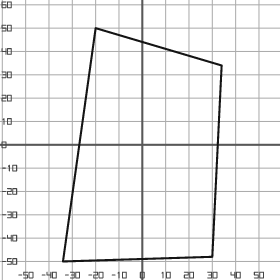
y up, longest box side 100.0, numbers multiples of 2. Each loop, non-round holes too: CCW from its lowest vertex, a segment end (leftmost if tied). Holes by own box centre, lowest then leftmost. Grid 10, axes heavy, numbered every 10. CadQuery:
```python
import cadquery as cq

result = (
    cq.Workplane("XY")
    .moveTo(-34.0, -50.0)
    .lineTo(30.0, -48.0)
    .lineTo(34.0, 34.0)
    .lineTo(-20.0, 50.0)
    .close()
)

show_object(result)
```